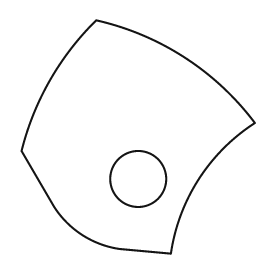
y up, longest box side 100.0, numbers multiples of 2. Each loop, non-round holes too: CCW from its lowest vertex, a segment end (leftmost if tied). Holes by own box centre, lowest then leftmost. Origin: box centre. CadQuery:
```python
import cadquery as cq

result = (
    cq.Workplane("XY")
    .moveTo(14.0, -50.0)
    .threePointArc((26.0, -18.0), (50.0, 6.0))
    .threePointArc((20.0, 34.0), (-18.0, 50.0))
    .threePointArc((-38.0, 24.0), (-50.0, -6.0))
    .lineTo(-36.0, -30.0)
    .threePointArc((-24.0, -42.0), (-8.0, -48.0))
    .close()
    .moveTo(0.0, -18.0)
    .circle(12.0)
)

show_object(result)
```